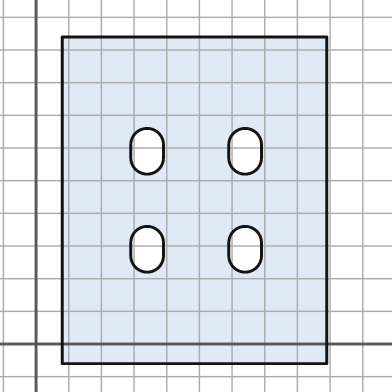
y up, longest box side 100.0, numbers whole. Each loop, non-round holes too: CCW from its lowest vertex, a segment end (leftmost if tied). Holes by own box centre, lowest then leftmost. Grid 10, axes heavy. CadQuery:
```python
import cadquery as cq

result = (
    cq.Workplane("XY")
    .moveTo(8.0, -6.0)
    .lineTo(89.0, -6.0)
    .lineTo(89.0, 94.0)
    .lineTo(8.0, 94.0)
    .close()
    .moveTo(29.0, 27.0)
    .threePointArc((34.0, 22.0), (39.0, 27.0))
    .lineTo(39.0, 31.0)
    .threePointArc((34.0, 36.0), (29.0, 31.0))
    .close()
    .moveTo(59.0, 27.0)
    .threePointArc((64.0, 22.0), (69.0, 27.0))
    .lineTo(69.0, 31.0)
    .threePointArc((64.0, 36.0), (59.0, 31.0))
    .close()
    .moveTo(29.0, 57.0)
    .threePointArc((34.0, 52.0), (39.0, 57.0))
    .lineTo(39.0, 61.0)
    .threePointArc((34.0, 66.0), (29.0, 61.0))
    .close()
    .moveTo(59.0, 57.0)
    .threePointArc((64.0, 52.0), (69.0, 57.0))
    .lineTo(69.0, 61.0)
    .threePointArc((64.0, 66.0), (59.0, 61.0))
    .close()
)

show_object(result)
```